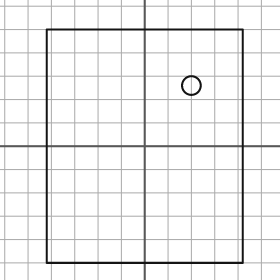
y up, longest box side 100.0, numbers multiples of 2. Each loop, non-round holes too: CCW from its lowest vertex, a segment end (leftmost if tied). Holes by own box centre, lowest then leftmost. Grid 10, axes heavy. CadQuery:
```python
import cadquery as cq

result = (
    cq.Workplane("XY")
    .moveTo(-42.0, -50.0)
    .lineTo(42.0, -50.0)
    .lineTo(42.0, 50.0)
    .lineTo(-42.0, 50.0)
    .close()
    .moveTo(20.0, 26.0)
    .circle(4.0)
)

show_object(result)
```